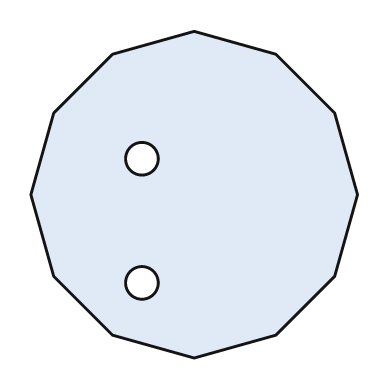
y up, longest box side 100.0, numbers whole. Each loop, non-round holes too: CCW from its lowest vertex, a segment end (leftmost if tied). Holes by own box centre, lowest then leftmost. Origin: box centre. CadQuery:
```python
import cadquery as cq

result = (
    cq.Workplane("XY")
    .moveTo(0.0, -50.0)
    .lineTo(25.0, -43.0)
    .lineTo(43.0, -25.0)
    .lineTo(50.0, 0.0)
    .lineTo(43.0, 25.0)
    .lineTo(25.0, 43.0)
    .lineTo(0.0, 50.0)
    .lineTo(-25.0, 43.0)
    .lineTo(-43.0, 25.0)
    .lineTo(-50.0, 0.0)
    .lineTo(-43.0, -25.0)
    .lineTo(-25.0, -43.0)
    .close()
    .moveTo(-16.0, -27.0)
    .circle(5.0)
    .moveTo(-16.0, 11.0)
    .circle(5.0)
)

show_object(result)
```